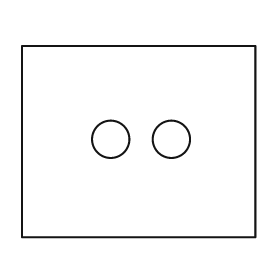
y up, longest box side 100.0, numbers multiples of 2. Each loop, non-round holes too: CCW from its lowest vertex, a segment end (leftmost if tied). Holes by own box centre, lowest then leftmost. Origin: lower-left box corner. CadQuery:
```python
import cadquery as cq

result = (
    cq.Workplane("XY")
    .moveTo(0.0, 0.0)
    .lineTo(100.0, 0.0)
    .lineTo(100.0, 82.0)
    .lineTo(0.0, 82.0)
    .close()
    .moveTo(38.0, 42.0)
    .circle(8.0)
    .moveTo(64.0, 42.0)
    .circle(8.0)
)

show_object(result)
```